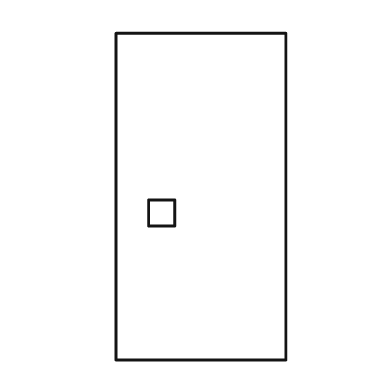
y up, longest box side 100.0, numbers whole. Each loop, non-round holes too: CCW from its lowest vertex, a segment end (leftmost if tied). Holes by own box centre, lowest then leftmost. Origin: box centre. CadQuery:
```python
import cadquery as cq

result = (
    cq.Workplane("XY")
    .moveTo(-26.0, -50.0)
    .lineTo(26.0, -50.0)
    .lineTo(26.0, 50.0)
    .lineTo(-26.0, 50.0)
    .close()
    .moveTo(-16.0, -9.0)
    .lineTo(-8.0, -9.0)
    .lineTo(-8.0, -1.0)
    .lineTo(-16.0, -1.0)
    .close()
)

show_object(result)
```